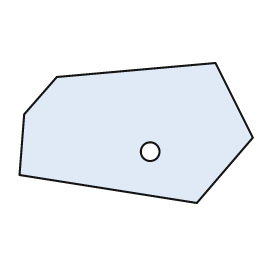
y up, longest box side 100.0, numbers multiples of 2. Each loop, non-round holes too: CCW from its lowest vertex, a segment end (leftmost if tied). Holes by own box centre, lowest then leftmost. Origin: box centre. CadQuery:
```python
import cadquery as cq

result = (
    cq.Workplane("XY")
    .moveTo(26.0, -30.0)
    .lineTo(50.0, -2.0)
    .lineTo(34.0, 30.0)
    .lineTo(-34.0, 24.0)
    .lineTo(-48.0, 8.0)
    .lineTo(-50.0, -18.0)
    .close()
    .moveTo(6.0, -8.0)
    .circle(4.0)
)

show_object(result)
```